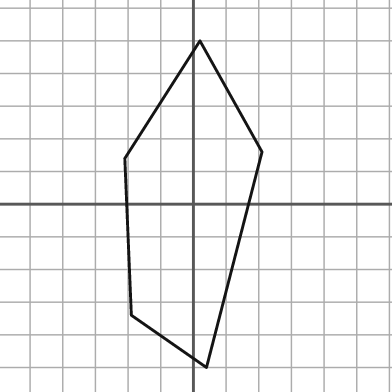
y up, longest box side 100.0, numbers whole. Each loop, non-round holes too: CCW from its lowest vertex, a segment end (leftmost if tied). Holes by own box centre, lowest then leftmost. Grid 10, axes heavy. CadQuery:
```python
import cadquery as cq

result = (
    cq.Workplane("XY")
    .moveTo(4.0, -50.0)
    .lineTo(21.0, 16.0)
    .lineTo(2.0, 50.0)
    .lineTo(-21.0, 14.0)
    .lineTo(-19.0, -34.0)
    .close()
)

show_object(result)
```